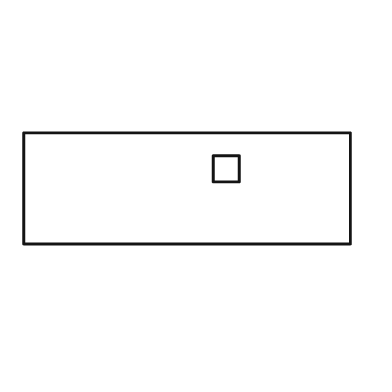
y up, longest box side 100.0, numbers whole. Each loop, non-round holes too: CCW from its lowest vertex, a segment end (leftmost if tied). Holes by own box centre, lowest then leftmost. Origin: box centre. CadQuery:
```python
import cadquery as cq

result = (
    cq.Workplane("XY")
    .moveTo(-50.0, -17.0)
    .lineTo(50.0, -17.0)
    .lineTo(50.0, 17.0)
    .lineTo(-50.0, 17.0)
    .close()
    .moveTo(8.0, 2.0)
    .lineTo(16.0, 2.0)
    .lineTo(16.0, 10.0)
    .lineTo(8.0, 10.0)
    .close()
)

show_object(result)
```